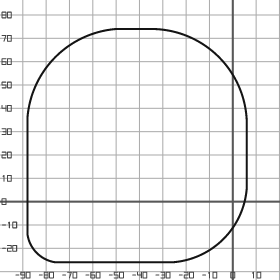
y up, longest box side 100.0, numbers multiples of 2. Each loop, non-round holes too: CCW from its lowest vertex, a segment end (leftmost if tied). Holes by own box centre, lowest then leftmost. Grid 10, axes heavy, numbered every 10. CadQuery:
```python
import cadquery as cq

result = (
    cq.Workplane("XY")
    .moveTo(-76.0, -26.0)
    .lineTo(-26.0, -26.0)
    .threePointArc((-4.0, -16.0), (6.0, 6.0))
    .lineTo(6.0, 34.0)
    .threePointArc((-6.0, 62.0), (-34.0, 74.0))
    .lineTo(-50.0, 74.0)
    .threePointArc((-76.0, 62.0), (-88.0, 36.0))
    .lineTo(-88.0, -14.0)
    .threePointArc((-84.0, -22.0), (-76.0, -26.0))
    .close()
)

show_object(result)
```